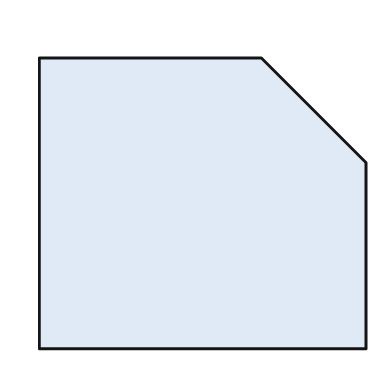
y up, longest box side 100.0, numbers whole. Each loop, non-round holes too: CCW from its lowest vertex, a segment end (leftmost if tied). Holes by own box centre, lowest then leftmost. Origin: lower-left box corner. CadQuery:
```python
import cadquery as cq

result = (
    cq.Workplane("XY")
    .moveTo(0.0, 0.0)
    .lineTo(100.0, 0.0)
    .lineTo(100.0, 57.0)
    .lineTo(68.0, 89.0)
    .lineTo(0.0, 89.0)
    .close()
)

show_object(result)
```